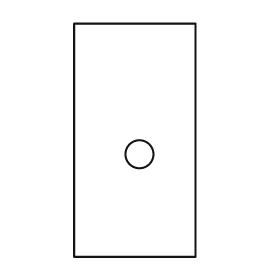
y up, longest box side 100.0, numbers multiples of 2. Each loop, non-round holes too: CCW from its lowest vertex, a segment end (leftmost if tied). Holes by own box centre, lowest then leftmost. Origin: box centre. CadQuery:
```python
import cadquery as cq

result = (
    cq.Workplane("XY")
    .moveTo(-26.0, -50.0)
    .lineTo(26.0, -50.0)
    .lineTo(26.0, 50.0)
    .lineTo(-26.0, 50.0)
    .close()
    .moveTo(2.0, -6.0)
    .circle(6.0)
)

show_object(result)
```